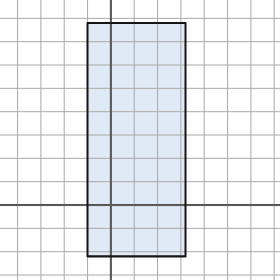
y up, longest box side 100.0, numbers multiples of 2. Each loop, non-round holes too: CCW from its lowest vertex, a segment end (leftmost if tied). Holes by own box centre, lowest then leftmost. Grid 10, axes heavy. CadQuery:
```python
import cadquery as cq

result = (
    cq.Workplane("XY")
    .moveTo(-10.0, -22.0)
    .lineTo(32.0, -22.0)
    .lineTo(32.0, 78.0)
    .lineTo(-10.0, 78.0)
    .close()
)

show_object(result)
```